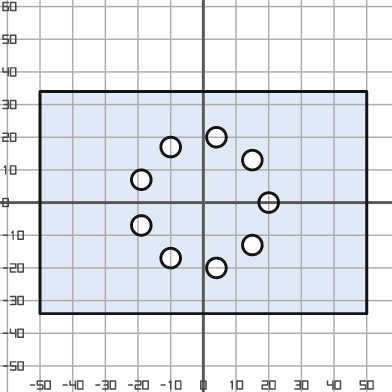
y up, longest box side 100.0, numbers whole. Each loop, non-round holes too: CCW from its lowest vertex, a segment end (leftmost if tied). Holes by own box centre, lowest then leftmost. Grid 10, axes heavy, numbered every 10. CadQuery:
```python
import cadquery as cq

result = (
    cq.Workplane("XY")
    .moveTo(-50.0, -34.0)
    .lineTo(50.0, -34.0)
    .lineTo(50.0, 34.0)
    .lineTo(-50.0, 34.0)
    .close()
    .moveTo(4.0, -20.0)
    .circle(3.0)
    .moveTo(-10.0, -17.0)
    .circle(3.0)
    .moveTo(15.0, -13.0)
    .circle(3.0)
    .moveTo(-19.0, -7.0)
    .circle(3.0)
    .moveTo(20.0, 0.0)
    .circle(3.0)
    .moveTo(-19.0, 7.0)
    .circle(3.0)
    .moveTo(15.0, 13.0)
    .circle(3.0)
    .moveTo(-10.0, 17.0)
    .circle(3.0)
    .moveTo(4.0, 20.0)
    .circle(3.0)
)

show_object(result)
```